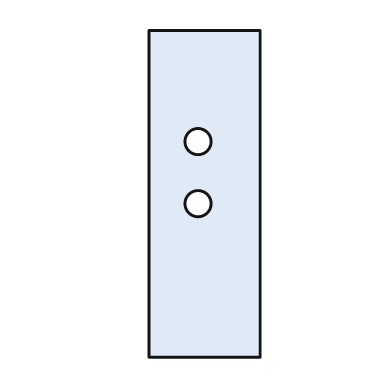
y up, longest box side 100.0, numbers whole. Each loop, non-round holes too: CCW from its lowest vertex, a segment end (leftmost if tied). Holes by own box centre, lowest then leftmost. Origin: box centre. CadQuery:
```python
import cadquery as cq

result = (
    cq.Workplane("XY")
    .moveTo(-17.0, -50.0)
    .lineTo(17.0, -50.0)
    .lineTo(17.0, 50.0)
    .lineTo(-17.0, 50.0)
    .close()
    .moveTo(-2.0, -3.0)
    .circle(4.0)
    .moveTo(-2.0, 16.0)
    .circle(4.0)
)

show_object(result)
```